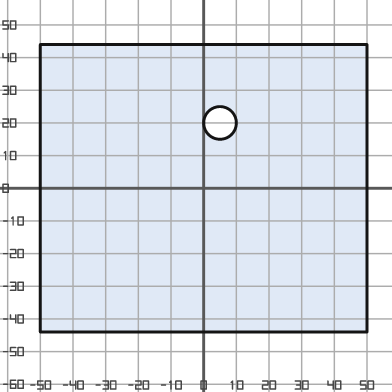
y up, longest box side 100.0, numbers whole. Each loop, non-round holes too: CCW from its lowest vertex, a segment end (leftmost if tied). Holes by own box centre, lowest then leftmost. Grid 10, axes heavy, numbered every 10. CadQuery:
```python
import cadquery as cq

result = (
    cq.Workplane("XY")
    .moveTo(-50.0, -44.0)
    .lineTo(50.0, -44.0)
    .lineTo(50.0, 44.0)
    .lineTo(-50.0, 44.0)
    .close()
    .moveTo(5.0, 20.0)
    .circle(5.0)
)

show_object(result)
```